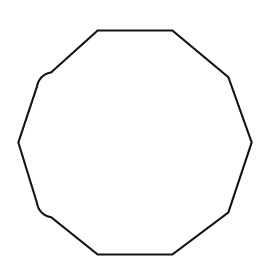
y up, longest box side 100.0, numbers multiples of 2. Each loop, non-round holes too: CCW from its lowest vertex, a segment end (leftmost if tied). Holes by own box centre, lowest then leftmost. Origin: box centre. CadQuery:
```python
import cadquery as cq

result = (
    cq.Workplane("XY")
    .moveTo(-16.0, -48.0)
    .lineTo(16.0, -48.0)
    .lineTo(40.0, -30.0)
    .lineTo(50.0, 0.0)
    .lineTo(40.0, 28.0)
    .lineTo(16.0, 48.0)
    .lineTo(-16.0, 48.0)
    .lineTo(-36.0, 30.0)
    .threePointArc((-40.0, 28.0), (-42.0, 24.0))
    .lineTo(-50.0, 0.0)
    .lineTo(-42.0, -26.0)
    .threePointArc((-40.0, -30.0), (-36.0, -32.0))
    .close()
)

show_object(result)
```